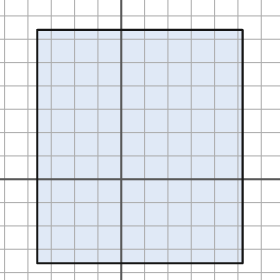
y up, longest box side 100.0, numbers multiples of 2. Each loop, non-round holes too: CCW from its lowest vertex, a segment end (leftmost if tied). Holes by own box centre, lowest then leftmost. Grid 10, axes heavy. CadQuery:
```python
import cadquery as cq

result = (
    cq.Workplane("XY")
    .moveTo(-36.0, -36.0)
    .lineTo(52.0, -36.0)
    .lineTo(52.0, 64.0)
    .lineTo(-36.0, 64.0)
    .close()
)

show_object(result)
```